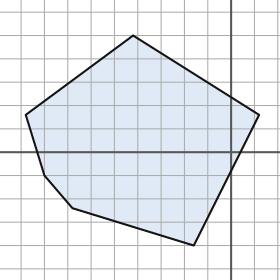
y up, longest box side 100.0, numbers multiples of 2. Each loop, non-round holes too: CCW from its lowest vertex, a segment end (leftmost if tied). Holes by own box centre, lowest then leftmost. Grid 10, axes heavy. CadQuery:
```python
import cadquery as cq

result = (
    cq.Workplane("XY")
    .moveTo(-16.0, -40.0)
    .lineTo(12.0, 16.0)
    .lineTo(-42.0, 50.0)
    .lineTo(-88.0, 16.0)
    .lineTo(-80.0, -10.0)
    .lineTo(-68.0, -24.0)
    .close()
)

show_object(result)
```